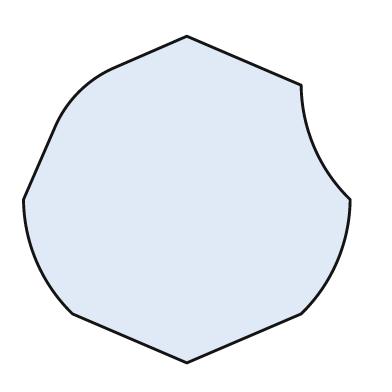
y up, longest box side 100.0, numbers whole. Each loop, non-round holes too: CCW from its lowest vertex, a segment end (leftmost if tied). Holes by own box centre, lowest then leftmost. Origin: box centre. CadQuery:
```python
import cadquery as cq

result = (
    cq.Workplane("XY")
    .moveTo(0.0, -50.0)
    .lineTo(35.0, -35.0)
    .threePointArc((46.0, -19.0), (50.0, 0.0))
    .threePointArc((39.0, 16.0), (35.0, 35.0))
    .lineTo(0.0, 50.0)
    .lineTo(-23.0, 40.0)
    .threePointArc((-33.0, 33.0), (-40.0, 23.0))
    .lineTo(-50.0, 0.0)
    .threePointArc((-46.0, -19.0), (-35.0, -35.0))
    .close()
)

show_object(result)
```